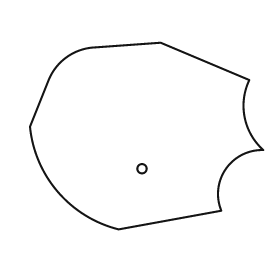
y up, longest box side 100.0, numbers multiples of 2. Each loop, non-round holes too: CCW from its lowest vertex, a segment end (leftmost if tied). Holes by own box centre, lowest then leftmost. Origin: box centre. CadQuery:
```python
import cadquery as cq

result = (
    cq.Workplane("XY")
    .moveTo(-12.0, -40.0)
    .lineTo(32.0, -32.0)
    .threePointArc((34.0, -14.0), (50.0, -6.0))
    .threePointArc((42.0, 8.0), (44.0, 24.0))
    .lineTo(6.0, 40.0)
    .lineTo(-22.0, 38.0)
    .threePointArc((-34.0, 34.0), (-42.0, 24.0))
    .lineTo(-50.0, 4.0)
    .threePointArc((-38.0, -24.0), (-12.0, -40.0))
    .close()
    .moveTo(-2.0, -14.0)
    .circle(2.0)
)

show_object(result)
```